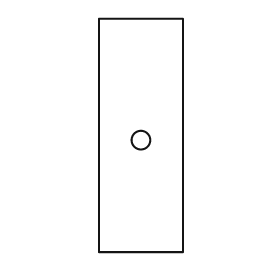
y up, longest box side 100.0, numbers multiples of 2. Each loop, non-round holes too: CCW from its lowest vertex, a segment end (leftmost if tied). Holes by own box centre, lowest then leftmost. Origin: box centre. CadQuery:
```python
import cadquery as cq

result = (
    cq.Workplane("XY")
    .moveTo(-18.0, -50.0)
    .lineTo(18.0, -50.0)
    .lineTo(18.0, 50.0)
    .lineTo(-18.0, 50.0)
    .close()
    .moveTo(0.0, -2.0)
    .circle(4.0)
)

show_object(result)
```